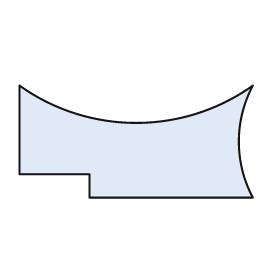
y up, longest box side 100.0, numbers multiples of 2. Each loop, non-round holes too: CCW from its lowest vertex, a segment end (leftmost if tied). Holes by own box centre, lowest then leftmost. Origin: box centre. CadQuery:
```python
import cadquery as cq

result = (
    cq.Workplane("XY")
    .moveTo(-20.0, -24.0)
    .lineTo(50.0, -24.0)
    .threePointArc((44.0, 0.0), (50.0, 24.0))
    .threePointArc((0.0, 8.0), (-50.0, 24.0))
    .lineTo(-50.0, -14.0)
    .lineTo(-20.0, -14.0)
    .close()
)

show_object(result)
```